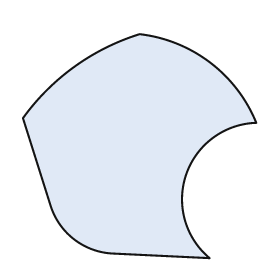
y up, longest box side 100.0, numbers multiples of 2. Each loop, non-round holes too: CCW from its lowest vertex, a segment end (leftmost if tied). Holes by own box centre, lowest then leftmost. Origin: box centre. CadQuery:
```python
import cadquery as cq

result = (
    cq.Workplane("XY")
    .moveTo(30.0, -48.0)
    .threePointArc((20.0, -12.0), (50.0, 10.0))
    .threePointArc((30.0, 36.0), (0.0, 48.0))
    .threePointArc((-28.0, 34.0), (-50.0, 12.0))
    .lineTo(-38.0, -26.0)
    .threePointArc((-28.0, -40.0), (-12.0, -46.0))
    .close()
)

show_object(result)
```